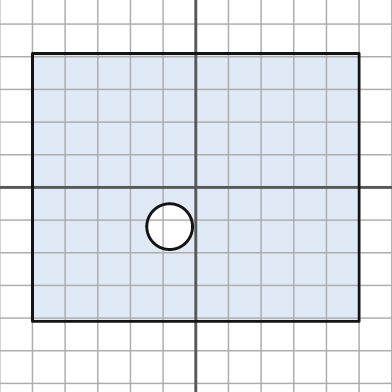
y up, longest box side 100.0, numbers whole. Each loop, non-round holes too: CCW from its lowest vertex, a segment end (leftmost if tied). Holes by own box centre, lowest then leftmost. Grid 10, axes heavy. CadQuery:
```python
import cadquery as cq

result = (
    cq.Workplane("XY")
    .moveTo(-50.0, -41.0)
    .lineTo(50.0, -41.0)
    .lineTo(50.0, 41.0)
    .lineTo(-50.0, 41.0)
    .close()
    .moveTo(-8.0, -12.0)
    .circle(7.0)
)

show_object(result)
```